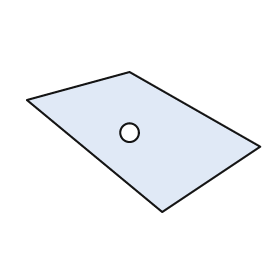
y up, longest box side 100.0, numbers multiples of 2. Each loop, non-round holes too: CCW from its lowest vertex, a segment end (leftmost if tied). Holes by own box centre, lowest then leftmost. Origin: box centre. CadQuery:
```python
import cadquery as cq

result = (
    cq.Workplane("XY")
    .moveTo(8.0, -30.0)
    .lineTo(50.0, -2.0)
    .lineTo(-6.0, 30.0)
    .lineTo(-50.0, 18.0)
    .close()
    .moveTo(-6.0, 4.0)
    .circle(4.0)
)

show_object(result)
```